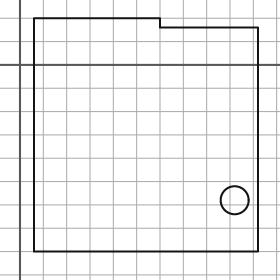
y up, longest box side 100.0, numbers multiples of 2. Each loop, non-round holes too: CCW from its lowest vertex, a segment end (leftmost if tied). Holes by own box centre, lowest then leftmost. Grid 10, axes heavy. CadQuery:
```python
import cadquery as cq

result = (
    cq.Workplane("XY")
    .moveTo(6.0, -80.0)
    .lineTo(102.0, -80.0)
    .lineTo(102.0, 16.0)
    .lineTo(60.0, 16.0)
    .lineTo(60.0, 20.0)
    .lineTo(6.0, 20.0)
    .close()
    .moveTo(92.0, -58.0)
    .circle(6.0)
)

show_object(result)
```